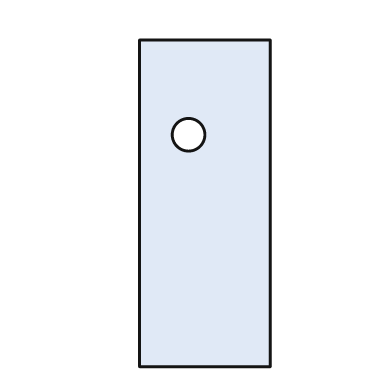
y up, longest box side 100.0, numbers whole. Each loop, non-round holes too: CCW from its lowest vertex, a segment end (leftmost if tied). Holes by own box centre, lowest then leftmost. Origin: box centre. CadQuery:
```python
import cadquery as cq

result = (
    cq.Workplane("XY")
    .moveTo(-20.0, -50.0)
    .lineTo(20.0, -50.0)
    .lineTo(20.0, 50.0)
    .lineTo(-20.0, 50.0)
    .close()
    .moveTo(-5.0, 21.0)
    .circle(5.0)
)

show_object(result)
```